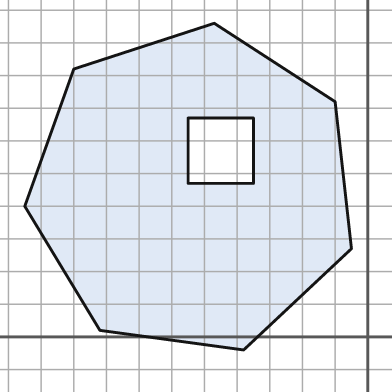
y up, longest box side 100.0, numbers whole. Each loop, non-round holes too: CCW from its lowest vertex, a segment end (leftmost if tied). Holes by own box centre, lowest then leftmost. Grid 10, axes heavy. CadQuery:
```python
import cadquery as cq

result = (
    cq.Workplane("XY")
    .moveTo(-38.0, -4.0)
    .lineTo(-5.0, 27.0)
    .lineTo(-10.0, 72.0)
    .lineTo(-47.0, 96.0)
    .lineTo(-90.0, 82.0)
    .lineTo(-105.0, 40.0)
    .lineTo(-82.0, 2.0)
    .close()
    .moveTo(-55.0, 47.0)
    .lineTo(-35.0, 47.0)
    .lineTo(-35.0, 67.0)
    .lineTo(-55.0, 67.0)
    .close()
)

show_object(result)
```